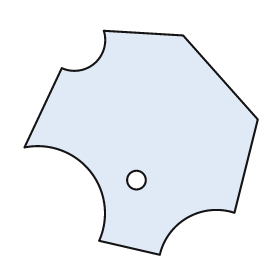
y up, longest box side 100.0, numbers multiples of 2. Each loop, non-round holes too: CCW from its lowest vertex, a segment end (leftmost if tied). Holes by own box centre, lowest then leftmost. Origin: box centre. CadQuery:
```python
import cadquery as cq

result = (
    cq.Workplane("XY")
    .moveTo(8.0, -48.0)
    .threePointArc((20.0, -32.0), (40.0, -30.0))
    .lineTo(50.0, 10.0)
    .lineTo(18.0, 46.0)
    .lineTo(-16.0, 48.0)
    .threePointArc((-20.0, 34.0), (-34.0, 32.0))
    .lineTo(-50.0, -2.0)
    .threePointArc((-22.0, -12.0), (-18.0, -42.0))
    .close()
    .moveTo(-2.0, -16.0)
    .circle(4.0)
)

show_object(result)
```